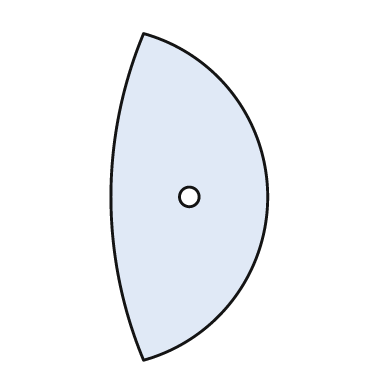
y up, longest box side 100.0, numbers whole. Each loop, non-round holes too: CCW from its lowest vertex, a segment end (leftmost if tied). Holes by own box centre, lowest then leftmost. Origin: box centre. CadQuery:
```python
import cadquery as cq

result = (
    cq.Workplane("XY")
    .moveTo(-14.0, -50.0)
    .threePointArc((24.0, 0.0), (-14.0, 50.0))
    .threePointArc((-24.0, 0.0), (-14.0, -50.0))
    .close()
    .moveTo(0.0, 0.0)
    .circle(3.0)
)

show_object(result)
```